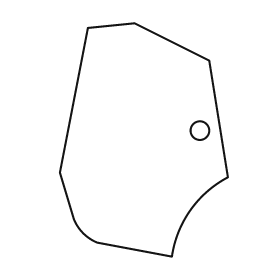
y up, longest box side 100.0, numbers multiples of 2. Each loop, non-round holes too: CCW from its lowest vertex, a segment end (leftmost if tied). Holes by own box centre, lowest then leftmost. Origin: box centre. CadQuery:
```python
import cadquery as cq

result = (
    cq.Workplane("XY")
    .moveTo(12.0, -50.0)
    .threePointArc((20.0, -30.0), (36.0, -16.0))
    .lineTo(28.0, 34.0)
    .lineTo(-4.0, 50.0)
    .lineTo(-24.0, 48.0)
    .lineTo(-36.0, -14.0)
    .lineTo(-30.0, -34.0)
    .threePointArc((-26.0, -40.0), (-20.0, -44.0))
    .close()
    .moveTo(24.0, 4.0)
    .circle(4.0)
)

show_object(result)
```